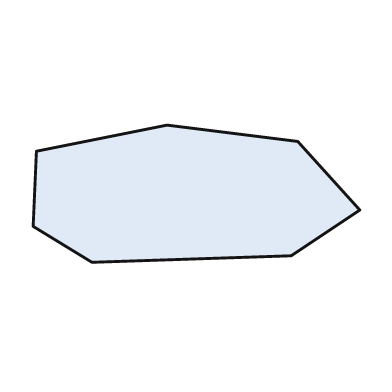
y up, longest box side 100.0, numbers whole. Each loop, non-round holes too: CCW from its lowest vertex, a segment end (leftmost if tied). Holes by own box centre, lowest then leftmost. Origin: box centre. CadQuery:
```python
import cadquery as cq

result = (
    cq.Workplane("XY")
    .moveTo(-32.0, -21.0)
    .lineTo(29.0, -19.0)
    .lineTo(50.0, -5.0)
    .lineTo(31.0, 16.0)
    .lineTo(-9.0, 21.0)
    .lineTo(-49.0, 13.0)
    .lineTo(-50.0, -10.0)
    .close()
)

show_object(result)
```